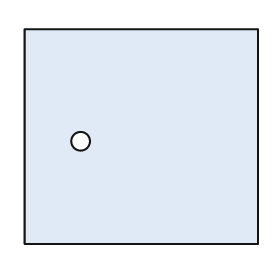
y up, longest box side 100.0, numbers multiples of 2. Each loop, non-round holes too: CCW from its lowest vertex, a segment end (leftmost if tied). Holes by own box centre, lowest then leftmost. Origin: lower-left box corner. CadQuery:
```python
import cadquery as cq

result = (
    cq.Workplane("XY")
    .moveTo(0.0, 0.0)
    .lineTo(100.0, 0.0)
    .lineTo(100.0, 92.0)
    .lineTo(0.0, 92.0)
    .close()
    .moveTo(24.0, 44.0)
    .circle(4.0)
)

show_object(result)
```